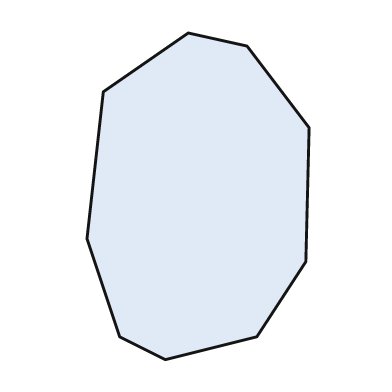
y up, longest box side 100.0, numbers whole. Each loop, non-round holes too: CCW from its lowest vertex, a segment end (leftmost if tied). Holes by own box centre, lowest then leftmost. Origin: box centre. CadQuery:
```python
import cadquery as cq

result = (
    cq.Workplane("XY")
    .moveTo(-10.0, -50.0)
    .lineTo(18.0, -43.0)
    .lineTo(33.0, -20.0)
    .lineTo(34.0, 21.0)
    .lineTo(15.0, 46.0)
    .lineTo(-3.0, 50.0)
    .lineTo(-29.0, 32.0)
    .lineTo(-34.0, -13.0)
    .lineTo(-24.0, -43.0)
    .close()
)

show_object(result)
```